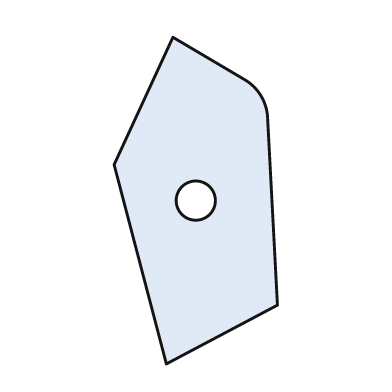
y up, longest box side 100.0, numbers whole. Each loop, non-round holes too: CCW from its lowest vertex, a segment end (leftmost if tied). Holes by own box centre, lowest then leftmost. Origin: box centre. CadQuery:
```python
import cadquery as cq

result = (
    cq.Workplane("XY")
    .moveTo(-9.0, -50.0)
    .lineTo(25.0, -32.0)
    .lineTo(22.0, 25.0)
    .threePointArc((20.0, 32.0), (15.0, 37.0))
    .lineTo(-7.0, 50.0)
    .lineTo(-25.0, 11.0)
    .close()
    .moveTo(0.0, 0.0)
    .circle(6.0)
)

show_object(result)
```